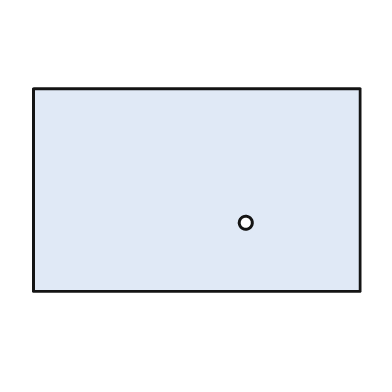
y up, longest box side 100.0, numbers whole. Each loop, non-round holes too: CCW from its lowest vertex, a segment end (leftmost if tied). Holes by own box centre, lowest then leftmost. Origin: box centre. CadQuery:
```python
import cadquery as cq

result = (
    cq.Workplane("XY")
    .moveTo(-50.0, -31.0)
    .lineTo(50.0, -31.0)
    .lineTo(50.0, 31.0)
    .lineTo(-50.0, 31.0)
    .close()
    .moveTo(15.0, -10.0)
    .circle(2.0)
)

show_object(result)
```